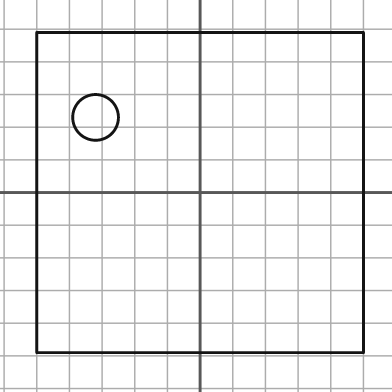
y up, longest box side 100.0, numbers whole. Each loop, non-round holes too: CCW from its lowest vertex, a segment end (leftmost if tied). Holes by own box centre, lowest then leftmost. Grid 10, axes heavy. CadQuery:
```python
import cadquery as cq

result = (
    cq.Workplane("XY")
    .moveTo(-50.0, -49.0)
    .lineTo(50.0, -49.0)
    .lineTo(50.0, 49.0)
    .lineTo(-50.0, 49.0)
    .close()
    .moveTo(-32.0, 23.0)
    .circle(7.0)
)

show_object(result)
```